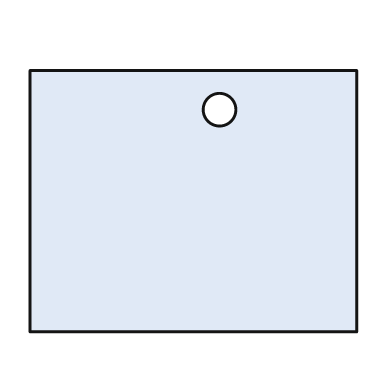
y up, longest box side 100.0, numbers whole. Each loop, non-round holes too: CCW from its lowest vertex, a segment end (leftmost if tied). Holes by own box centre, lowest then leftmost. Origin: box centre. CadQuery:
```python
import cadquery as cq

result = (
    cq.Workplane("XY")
    .moveTo(-50.0, -40.0)
    .lineTo(50.0, -40.0)
    .lineTo(50.0, 40.0)
    .lineTo(-50.0, 40.0)
    .close()
    .moveTo(8.0, 28.0)
    .circle(5.0)
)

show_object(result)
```